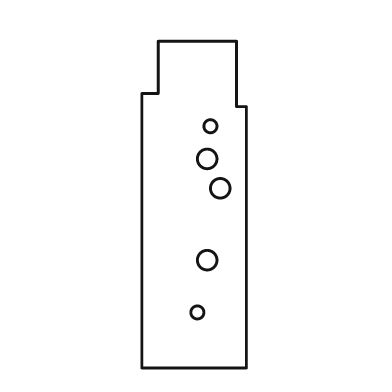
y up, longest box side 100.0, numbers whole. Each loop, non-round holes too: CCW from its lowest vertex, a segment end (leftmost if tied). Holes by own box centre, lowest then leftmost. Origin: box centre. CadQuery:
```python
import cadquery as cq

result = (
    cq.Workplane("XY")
    .moveTo(-16.0, -50.0)
    .lineTo(16.0, -50.0)
    .lineTo(16.0, 30.0)
    .lineTo(13.0, 30.0)
    .lineTo(13.0, 50.0)
    .lineTo(-11.0, 50.0)
    .lineTo(-11.0, 34.0)
    .lineTo(-16.0, 34.0)
    .close()
    .moveTo(1.0, -33.0)
    .circle(2.0)
    .moveTo(4.0, -17.0)
    .circle(3.0)
    .moveTo(8.0, 5.0)
    .circle(3.0)
    .moveTo(4.0, 14.0)
    .circle(3.0)
    .moveTo(5.0, 24.0)
    .circle(2.0)
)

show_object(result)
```